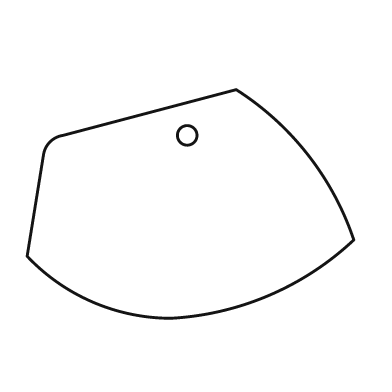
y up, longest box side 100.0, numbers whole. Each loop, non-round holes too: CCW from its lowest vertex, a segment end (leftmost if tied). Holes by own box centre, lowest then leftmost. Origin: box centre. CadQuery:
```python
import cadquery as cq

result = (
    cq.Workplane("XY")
    .moveTo(-6.0, -35.0)
    .threePointArc((24.0, -28.0), (50.0, -11.0))
    .threePointArc((36.0, 15.0), (14.0, 35.0))
    .lineTo(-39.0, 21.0)
    .threePointArc((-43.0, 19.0), (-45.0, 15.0))
    .lineTo(-50.0, -16.0)
    .threePointArc((-30.0, -30.0), (-6.0, -35.0))
    .close()
    .moveTo(-1.0, 21.0)
    .circle(3.0)
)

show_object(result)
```